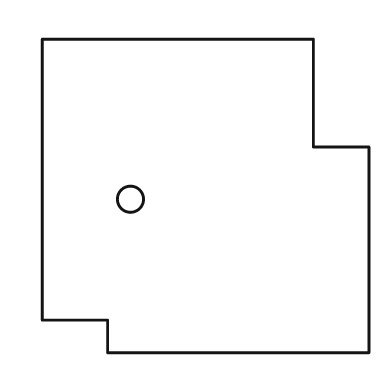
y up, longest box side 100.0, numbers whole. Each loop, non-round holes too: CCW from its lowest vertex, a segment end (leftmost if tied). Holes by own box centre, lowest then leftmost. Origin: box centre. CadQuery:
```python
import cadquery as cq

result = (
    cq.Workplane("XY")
    .moveTo(-30.0, -48.0)
    .lineTo(50.0, -48.0)
    .lineTo(50.0, 15.0)
    .lineTo(33.0, 15.0)
    .lineTo(33.0, 48.0)
    .lineTo(-50.0, 48.0)
    .lineTo(-50.0, -38.0)
    .lineTo(-30.0, -38.0)
    .close()
    .moveTo(-23.0, -1.0)
    .circle(4.0)
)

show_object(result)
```